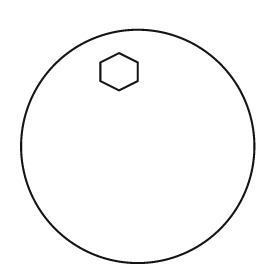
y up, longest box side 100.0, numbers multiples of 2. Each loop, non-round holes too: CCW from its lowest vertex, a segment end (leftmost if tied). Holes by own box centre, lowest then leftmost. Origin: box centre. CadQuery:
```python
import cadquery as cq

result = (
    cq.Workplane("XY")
    .moveTo(0.0, 0.0)
    .circle(50.0)
    .moveTo(-8.0, 24.0)
    .lineTo(0.0, 28.0)
    .lineTo(0.0, 36.0)
    .lineTo(-8.0, 40.0)
    .lineTo(-16.0, 36.0)
    .lineTo(-16.0, 28.0)
    .close()
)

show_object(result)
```